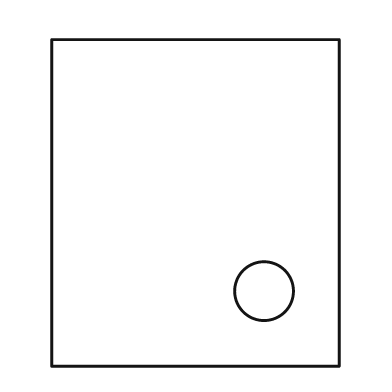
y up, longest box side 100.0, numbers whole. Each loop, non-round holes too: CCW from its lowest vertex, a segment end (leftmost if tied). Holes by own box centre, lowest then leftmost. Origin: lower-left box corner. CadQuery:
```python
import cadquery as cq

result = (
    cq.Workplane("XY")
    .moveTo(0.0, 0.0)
    .lineTo(88.0, 0.0)
    .lineTo(88.0, 100.0)
    .lineTo(0.0, 100.0)
    .close()
    .moveTo(65.0, 23.0)
    .circle(9.0)
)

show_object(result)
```